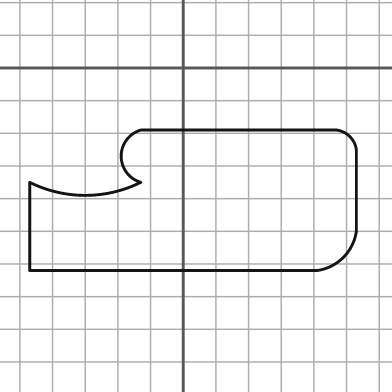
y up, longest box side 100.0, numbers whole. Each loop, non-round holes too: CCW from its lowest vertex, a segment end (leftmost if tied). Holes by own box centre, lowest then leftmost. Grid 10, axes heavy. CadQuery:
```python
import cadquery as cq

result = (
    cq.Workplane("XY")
    .moveTo(-47.0, -62.0)
    .lineTo(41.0, -62.0)
    .threePointArc((49.0, -58.0), (53.0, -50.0))
    .lineTo(53.0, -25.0)
    .threePointArc((51.0, -21.0), (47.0, -19.0))
    .lineTo(-13.0, -19.0)
    .threePointArc((-19.0, -27.0), (-13.0, -35.0))
    .threePointArc((-30.0, -39.0), (-47.0, -35.0))
    .close()
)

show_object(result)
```